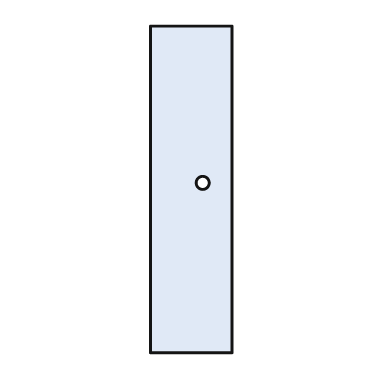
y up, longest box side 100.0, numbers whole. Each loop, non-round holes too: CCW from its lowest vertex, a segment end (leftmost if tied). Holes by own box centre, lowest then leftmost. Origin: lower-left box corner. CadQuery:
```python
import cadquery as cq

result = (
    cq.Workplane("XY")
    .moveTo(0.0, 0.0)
    .lineTo(25.0, 0.0)
    .lineTo(25.0, 100.0)
    .lineTo(0.0, 100.0)
    .close()
    .moveTo(16.0, 52.0)
    .circle(2.0)
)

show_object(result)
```